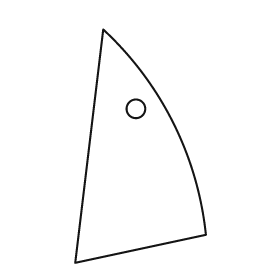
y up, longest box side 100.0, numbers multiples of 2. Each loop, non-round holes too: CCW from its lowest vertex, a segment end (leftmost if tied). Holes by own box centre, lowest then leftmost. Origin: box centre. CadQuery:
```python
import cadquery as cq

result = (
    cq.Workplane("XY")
    .moveTo(-28.0, -50.0)
    .lineTo(28.0, -38.0)
    .threePointArc((14.0, 10.0), (-16.0, 50.0))
    .close()
    .moveTo(-2.0, 16.0)
    .circle(4.0)
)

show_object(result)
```